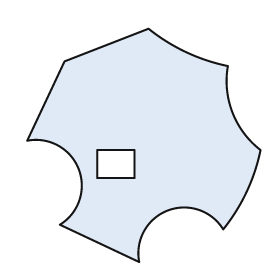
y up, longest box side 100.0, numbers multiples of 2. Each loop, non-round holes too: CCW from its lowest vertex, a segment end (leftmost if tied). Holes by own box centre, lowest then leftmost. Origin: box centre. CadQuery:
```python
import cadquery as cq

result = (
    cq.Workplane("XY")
    .moveTo(-2.0, -50.0)
    .threePointArc((10.0, -28.0), (34.0, -36.0))
    .threePointArc((44.0, -20.0), (50.0, -2.0))
    .threePointArc((38.0, 14.0), (36.0, 34.0))
    .threePointArc((18.0, 40.0), (2.0, 50.0))
    .lineTo(-34.0, 36.0)
    .lineTo(-50.0, 2.0)
    .threePointArc((-28.0, -10.0), (-36.0, -34.0))
    .close()
    .moveTo(-20.0, -14.0)
    .lineTo(-4.0, -14.0)
    .lineTo(-4.0, -2.0)
    .lineTo(-20.0, -2.0)
    .close()
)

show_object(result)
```